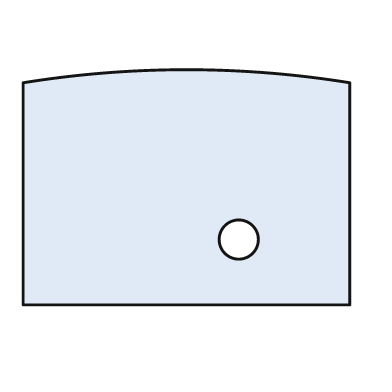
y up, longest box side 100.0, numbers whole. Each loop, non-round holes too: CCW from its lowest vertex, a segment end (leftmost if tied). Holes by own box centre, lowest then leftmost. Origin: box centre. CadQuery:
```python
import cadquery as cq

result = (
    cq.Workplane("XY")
    .moveTo(-50.0, -36.0)
    .lineTo(50.0, -36.0)
    .lineTo(50.0, 32.0)
    .threePointArc((0.0, 36.0), (-50.0, 32.0))
    .close()
    .moveTo(16.0, -16.0)
    .circle(6.0)
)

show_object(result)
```